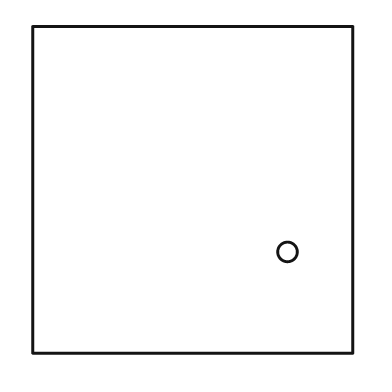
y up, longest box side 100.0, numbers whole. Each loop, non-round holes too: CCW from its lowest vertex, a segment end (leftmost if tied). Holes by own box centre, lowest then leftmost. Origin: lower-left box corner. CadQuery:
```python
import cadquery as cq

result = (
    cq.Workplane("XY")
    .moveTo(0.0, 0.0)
    .lineTo(98.0, 0.0)
    .lineTo(98.0, 100.0)
    .lineTo(0.0, 100.0)
    .close()
    .moveTo(78.0, 31.0)
    .circle(3.0)
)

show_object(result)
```